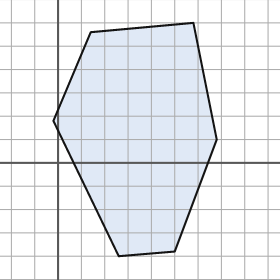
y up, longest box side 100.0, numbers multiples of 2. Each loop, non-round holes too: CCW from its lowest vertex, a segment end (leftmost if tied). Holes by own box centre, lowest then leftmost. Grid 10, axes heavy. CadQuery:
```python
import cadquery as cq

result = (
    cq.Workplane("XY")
    .moveTo(26.0, -40.0)
    .lineTo(50.0, -38.0)
    .lineTo(68.0, 10.0)
    .lineTo(58.0, 60.0)
    .lineTo(14.0, 56.0)
    .lineTo(-2.0, 18.0)
    .close()
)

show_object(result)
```